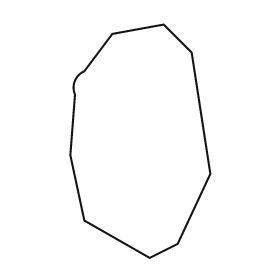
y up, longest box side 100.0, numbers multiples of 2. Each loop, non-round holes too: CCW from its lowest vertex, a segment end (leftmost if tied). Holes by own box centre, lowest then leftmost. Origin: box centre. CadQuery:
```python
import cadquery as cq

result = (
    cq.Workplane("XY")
    .moveTo(4.0, -50.0)
    .lineTo(16.0, -44.0)
    .lineTo(30.0, -14.0)
    .lineTo(22.0, 38.0)
    .lineTo(10.0, 50.0)
    .lineTo(-12.0, 46.0)
    .lineTo(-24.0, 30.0)
    .threePointArc((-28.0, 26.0), (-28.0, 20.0))
    .lineTo(-30.0, -6.0)
    .lineTo(-24.0, -34.0)
    .close()
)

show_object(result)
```